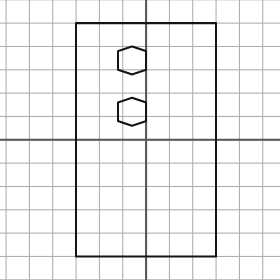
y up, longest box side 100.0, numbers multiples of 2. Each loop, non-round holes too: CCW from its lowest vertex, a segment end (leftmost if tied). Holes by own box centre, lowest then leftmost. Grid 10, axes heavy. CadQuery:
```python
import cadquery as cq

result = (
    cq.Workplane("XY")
    .moveTo(-30.0, -50.0)
    .lineTo(30.0, -50.0)
    .lineTo(30.0, 50.0)
    .lineTo(-30.0, 50.0)
    .close()
    .moveTo(-6.0, 6.0)
    .lineTo(0.0, 8.0)
    .lineTo(0.0, 16.0)
    .lineTo(-6.0, 18.0)
    .lineTo(-12.0, 16.0)
    .lineTo(-12.0, 8.0)
    .close()
    .moveTo(-6.0, 28.0)
    .lineTo(0.0, 30.0)
    .lineTo(0.0, 38.0)
    .lineTo(-6.0, 40.0)
    .lineTo(-12.0, 38.0)
    .lineTo(-12.0, 30.0)
    .close()
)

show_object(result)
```